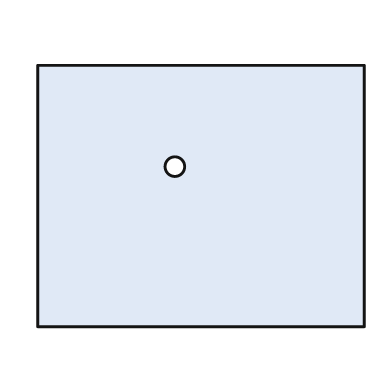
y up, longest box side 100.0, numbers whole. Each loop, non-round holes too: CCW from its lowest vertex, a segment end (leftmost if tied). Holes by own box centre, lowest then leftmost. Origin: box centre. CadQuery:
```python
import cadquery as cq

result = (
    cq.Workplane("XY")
    .moveTo(-50.0, -40.0)
    .lineTo(50.0, -40.0)
    .lineTo(50.0, 40.0)
    .lineTo(-50.0, 40.0)
    .close()
    .moveTo(-8.0, 9.0)
    .circle(3.0)
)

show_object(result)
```